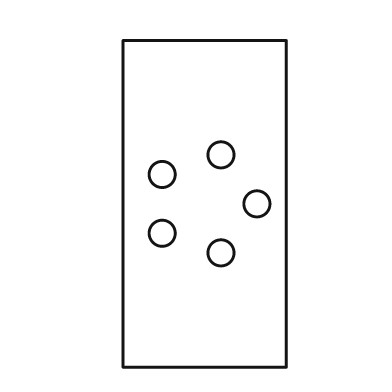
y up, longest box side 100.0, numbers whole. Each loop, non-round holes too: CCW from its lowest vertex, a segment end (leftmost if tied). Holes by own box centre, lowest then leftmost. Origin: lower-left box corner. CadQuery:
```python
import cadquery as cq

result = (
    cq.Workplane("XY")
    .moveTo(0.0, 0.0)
    .lineTo(50.0, 0.0)
    .lineTo(50.0, 100.0)
    .lineTo(0.0, 100.0)
    .close()
    .moveTo(30.0, 35.0)
    .circle(4.0)
    .moveTo(12.0, 41.0)
    .circle(4.0)
    .moveTo(41.0, 50.0)
    .circle(4.0)
    .moveTo(12.0, 59.0)
    .circle(4.0)
    .moveTo(30.0, 65.0)
    .circle(4.0)
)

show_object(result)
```